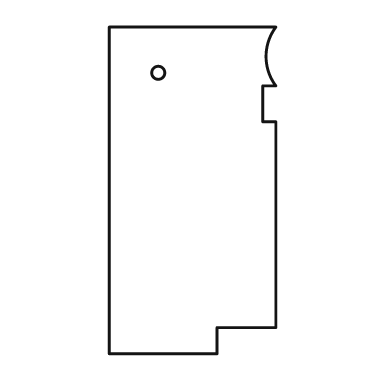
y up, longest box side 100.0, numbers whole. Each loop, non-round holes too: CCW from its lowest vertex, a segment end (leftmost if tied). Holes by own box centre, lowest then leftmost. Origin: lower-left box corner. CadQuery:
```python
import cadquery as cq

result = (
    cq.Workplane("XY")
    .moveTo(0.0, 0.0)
    .lineTo(33.0, 0.0)
    .lineTo(33.0, 8.0)
    .lineTo(51.0, 8.0)
    .lineTo(51.0, 71.0)
    .lineTo(47.0, 71.0)
    .lineTo(47.0, 82.0)
    .lineTo(51.0, 82.0)
    .threePointArc((48.0, 91.0), (51.0, 100.0))
    .lineTo(0.0, 100.0)
    .close()
    .moveTo(15.0, 86.0)
    .circle(2.0)
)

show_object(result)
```